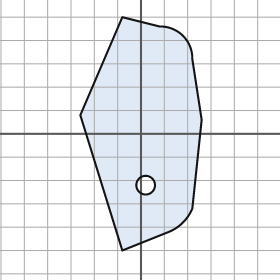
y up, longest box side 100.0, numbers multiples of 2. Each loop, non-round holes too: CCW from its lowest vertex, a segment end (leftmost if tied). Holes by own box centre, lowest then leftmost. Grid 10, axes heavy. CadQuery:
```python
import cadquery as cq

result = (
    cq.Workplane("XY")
    .moveTo(-8.0, -50.0)
    .lineTo(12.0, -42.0)
    .threePointArc((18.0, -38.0), (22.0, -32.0))
    .lineTo(26.0, 6.0)
    .lineTo(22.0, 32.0)
    .threePointArc((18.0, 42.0), (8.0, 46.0))
    .lineTo(-8.0, 50.0)
    .lineTo(-26.0, 8.0)
    .close()
    .moveTo(2.0, -22.0)
    .circle(4.0)
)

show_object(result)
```